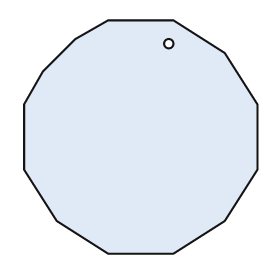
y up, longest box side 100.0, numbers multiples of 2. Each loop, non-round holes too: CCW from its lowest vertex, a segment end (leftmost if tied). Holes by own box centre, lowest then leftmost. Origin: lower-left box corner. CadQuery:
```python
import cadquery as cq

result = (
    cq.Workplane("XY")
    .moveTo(36.0, 0.0)
    .lineTo(64.0, 0.0)
    .lineTo(86.0, 14.0)
    .lineTo(100.0, 36.0)
    .lineTo(100.0, 64.0)
    .lineTo(86.0, 86.0)
    .lineTo(64.0, 100.0)
    .lineTo(36.0, 100.0)
    .lineTo(22.0, 92.0)
    .lineTo(8.0, 78.0)
    .lineTo(0.0, 64.0)
    .lineTo(0.0, 36.0)
    .lineTo(14.0, 14.0)
    .close()
    .moveTo(62.0, 90.0)
    .circle(2.0)
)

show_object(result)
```